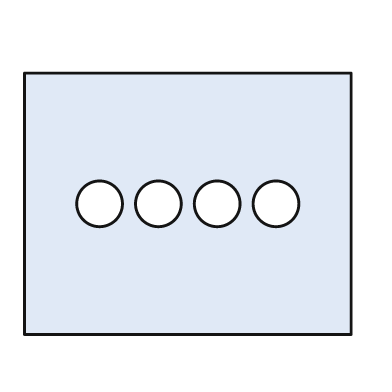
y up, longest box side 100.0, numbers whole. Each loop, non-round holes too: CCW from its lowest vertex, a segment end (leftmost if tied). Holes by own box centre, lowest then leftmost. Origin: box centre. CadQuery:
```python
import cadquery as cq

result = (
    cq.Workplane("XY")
    .moveTo(-50.0, -40.0)
    .lineTo(50.0, -40.0)
    .lineTo(50.0, 40.0)
    .lineTo(-50.0, 40.0)
    .close()
    .moveTo(-27.0, 0.0)
    .circle(7.0)
    .moveTo(-9.0, 0.0)
    .circle(7.0)
    .moveTo(9.0, 0.0)
    .circle(7.0)
    .moveTo(27.0, 0.0)
    .circle(7.0)
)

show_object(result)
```